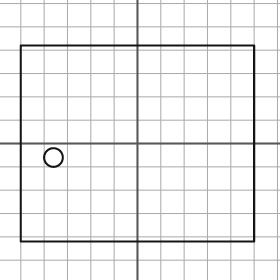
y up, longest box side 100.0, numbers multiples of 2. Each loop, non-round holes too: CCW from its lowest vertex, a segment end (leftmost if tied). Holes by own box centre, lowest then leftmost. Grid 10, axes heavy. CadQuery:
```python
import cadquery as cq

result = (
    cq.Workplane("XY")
    .moveTo(-50.0, -42.0)
    .lineTo(50.0, -42.0)
    .lineTo(50.0, 42.0)
    .lineTo(-50.0, 42.0)
    .close()
    .moveTo(-36.0, -6.0)
    .circle(4.0)
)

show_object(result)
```